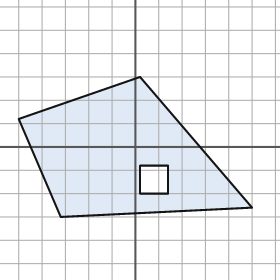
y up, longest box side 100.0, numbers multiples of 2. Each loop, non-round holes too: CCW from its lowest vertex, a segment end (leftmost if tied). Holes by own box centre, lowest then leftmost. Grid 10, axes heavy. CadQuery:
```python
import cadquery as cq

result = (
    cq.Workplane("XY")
    .moveTo(-32.0, -30.0)
    .lineTo(50.0, -26.0)
    .lineTo(2.0, 30.0)
    .lineTo(-50.0, 12.0)
    .close()
    .moveTo(2.0, -20.0)
    .lineTo(14.0, -20.0)
    .lineTo(14.0, -8.0)
    .lineTo(2.0, -8.0)
    .close()
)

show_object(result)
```